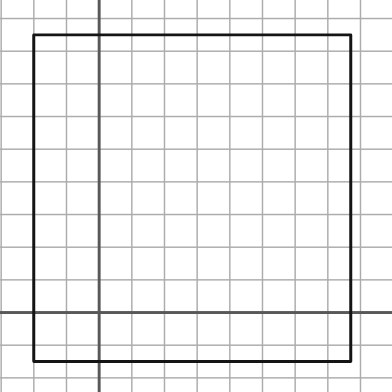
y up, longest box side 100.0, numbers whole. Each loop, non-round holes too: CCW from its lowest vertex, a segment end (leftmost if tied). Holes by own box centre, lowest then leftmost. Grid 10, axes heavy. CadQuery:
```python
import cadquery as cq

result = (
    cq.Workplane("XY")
    .moveTo(-20.0, -15.0)
    .lineTo(77.0, -15.0)
    .lineTo(77.0, 85.0)
    .lineTo(-20.0, 85.0)
    .close()
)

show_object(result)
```